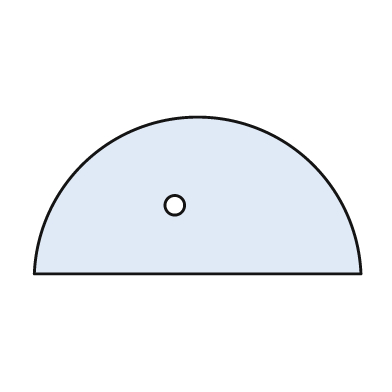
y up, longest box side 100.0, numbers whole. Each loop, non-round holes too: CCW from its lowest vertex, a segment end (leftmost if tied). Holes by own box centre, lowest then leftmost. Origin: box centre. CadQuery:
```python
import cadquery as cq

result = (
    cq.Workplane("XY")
    .moveTo(-50.0, -24.0)
    .lineTo(50.0, -24.0)
    .threePointArc((0.0, 24.0), (-50.0, -24.0))
    .close()
    .moveTo(-7.0, -3.0)
    .circle(3.0)
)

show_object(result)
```